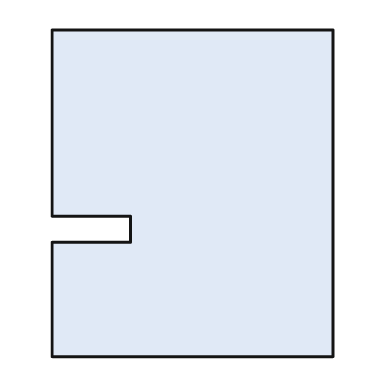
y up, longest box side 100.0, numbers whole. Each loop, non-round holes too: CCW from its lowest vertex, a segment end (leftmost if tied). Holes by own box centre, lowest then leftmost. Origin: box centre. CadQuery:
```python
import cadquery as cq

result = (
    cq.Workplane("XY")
    .moveTo(-43.0, -50.0)
    .lineTo(43.0, -50.0)
    .lineTo(43.0, 50.0)
    .lineTo(-43.0, 50.0)
    .lineTo(-43.0, -7.0)
    .lineTo(-19.0, -7.0)
    .lineTo(-19.0, -15.0)
    .lineTo(-43.0, -15.0)
    .close()
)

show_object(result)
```